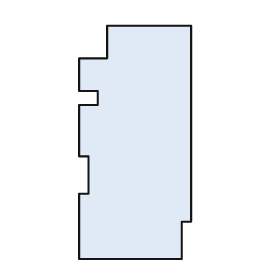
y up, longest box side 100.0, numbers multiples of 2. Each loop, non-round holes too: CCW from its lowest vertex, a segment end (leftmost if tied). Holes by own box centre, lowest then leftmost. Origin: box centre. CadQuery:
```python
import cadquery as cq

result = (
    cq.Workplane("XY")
    .moveTo(-24.0, -50.0)
    .lineTo(20.0, -50.0)
    .lineTo(20.0, -34.0)
    .lineTo(24.0, -34.0)
    .lineTo(24.0, 50.0)
    .lineTo(-12.0, 50.0)
    .lineTo(-12.0, 36.0)
    .lineTo(-24.0, 36.0)
    .lineTo(-24.0, 22.0)
    .lineTo(-16.0, 22.0)
    .lineTo(-16.0, 16.0)
    .lineTo(-24.0, 16.0)
    .lineTo(-24.0, -6.0)
    .lineTo(-20.0, -6.0)
    .lineTo(-20.0, -22.0)
    .lineTo(-24.0, -22.0)
    .close()
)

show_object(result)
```